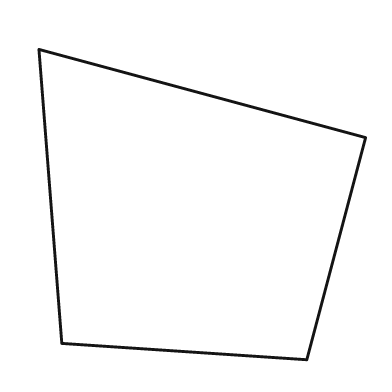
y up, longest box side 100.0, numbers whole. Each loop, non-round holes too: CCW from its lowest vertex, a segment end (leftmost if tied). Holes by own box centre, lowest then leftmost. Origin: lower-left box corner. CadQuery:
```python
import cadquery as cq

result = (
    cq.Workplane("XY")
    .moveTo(82.0, 0.0)
    .lineTo(100.0, 68.0)
    .lineTo(0.0, 95.0)
    .lineTo(7.0, 5.0)
    .close()
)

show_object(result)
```